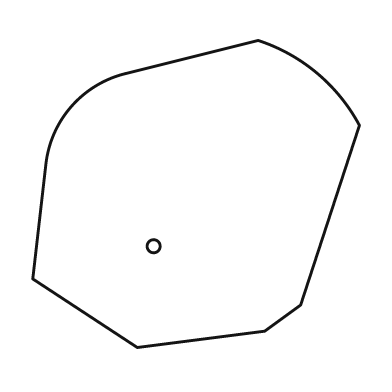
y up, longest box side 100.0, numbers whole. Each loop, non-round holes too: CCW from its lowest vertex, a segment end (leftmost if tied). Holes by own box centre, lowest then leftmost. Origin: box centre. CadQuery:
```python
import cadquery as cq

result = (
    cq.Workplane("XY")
    .moveTo(-18.0, -47.0)
    .lineTo(21.0, -42.0)
    .lineTo(32.0, -34.0)
    .lineTo(50.0, 21.0)
    .threePointArc((37.0, 37.0), (19.0, 47.0))
    .lineTo(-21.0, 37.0)
    .threePointArc((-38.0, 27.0), (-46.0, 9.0))
    .lineTo(-50.0, -26.0)
    .close()
    .moveTo(-13.0, -16.0)
    .circle(2.0)
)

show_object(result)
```